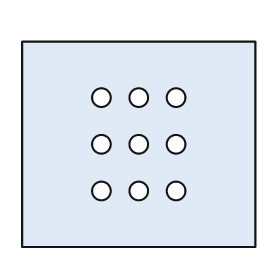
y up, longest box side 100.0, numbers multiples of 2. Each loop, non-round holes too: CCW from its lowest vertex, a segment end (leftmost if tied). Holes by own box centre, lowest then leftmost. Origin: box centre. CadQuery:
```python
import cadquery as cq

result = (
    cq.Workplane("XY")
    .moveTo(-50.0, -44.0)
    .lineTo(50.0, -44.0)
    .lineTo(50.0, 44.0)
    .lineTo(-50.0, 44.0)
    .close()
    .moveTo(-16.0, -20.0)
    .circle(4.0)
    .moveTo(0.0, -20.0)
    .circle(4.0)
    .moveTo(16.0, -20.0)
    .circle(4.0)
    .moveTo(-16.0, 0.0)
    .circle(4.0)
    .moveTo(0.0, 0.0)
    .circle(4.0)
    .moveTo(16.0, 0.0)
    .circle(4.0)
    .moveTo(-16.0, 20.0)
    .circle(4.0)
    .moveTo(0.0, 20.0)
    .circle(4.0)
    .moveTo(16.0, 20.0)
    .circle(4.0)
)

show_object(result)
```